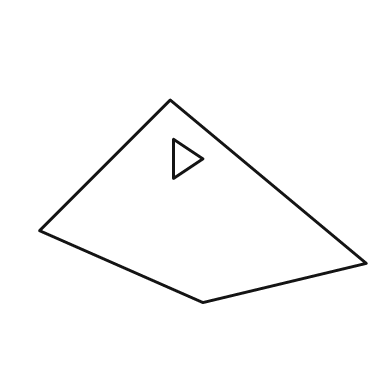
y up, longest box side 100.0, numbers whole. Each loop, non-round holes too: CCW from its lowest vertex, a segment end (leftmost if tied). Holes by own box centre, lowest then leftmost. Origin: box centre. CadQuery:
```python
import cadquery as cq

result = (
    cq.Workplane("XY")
    .moveTo(0.0, -31.0)
    .lineTo(50.0, -19.0)
    .lineTo(-10.0, 31.0)
    .lineTo(-50.0, -9.0)
    .close()
    .moveTo(-9.0, 7.0)
    .lineTo(0.0, 13.0)
    .lineTo(-9.0, 19.0)
    .close()
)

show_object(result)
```